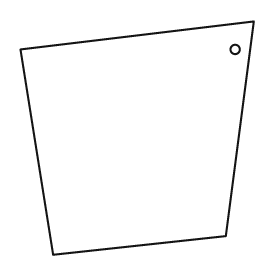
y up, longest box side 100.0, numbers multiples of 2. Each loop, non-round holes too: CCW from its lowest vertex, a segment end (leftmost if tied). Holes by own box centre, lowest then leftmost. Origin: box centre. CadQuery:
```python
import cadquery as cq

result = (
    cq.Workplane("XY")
    .moveTo(-36.0, -50.0)
    .lineTo(38.0, -42.0)
    .lineTo(50.0, 50.0)
    .lineTo(-50.0, 38.0)
    .close()
    .moveTo(42.0, 38.0)
    .circle(2.0)
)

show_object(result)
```